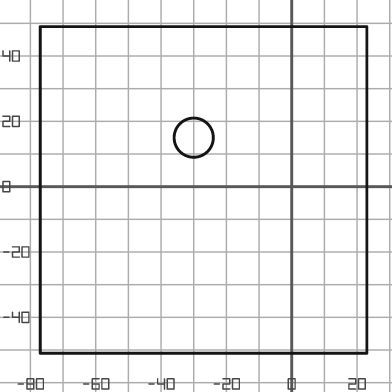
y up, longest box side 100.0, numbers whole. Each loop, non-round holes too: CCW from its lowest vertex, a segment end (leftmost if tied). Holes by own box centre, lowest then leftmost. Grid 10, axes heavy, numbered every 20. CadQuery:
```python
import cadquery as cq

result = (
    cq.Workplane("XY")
    .moveTo(-77.0, -51.0)
    .lineTo(23.0, -51.0)
    .lineTo(23.0, 49.0)
    .lineTo(-77.0, 49.0)
    .close()
    .moveTo(-30.0, 15.0)
    .circle(6.0)
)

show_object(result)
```